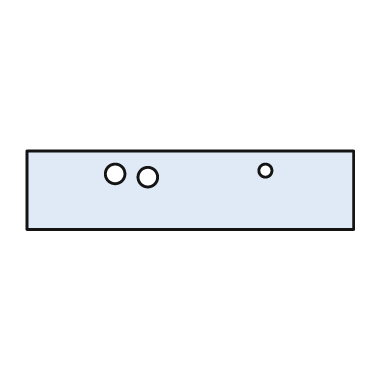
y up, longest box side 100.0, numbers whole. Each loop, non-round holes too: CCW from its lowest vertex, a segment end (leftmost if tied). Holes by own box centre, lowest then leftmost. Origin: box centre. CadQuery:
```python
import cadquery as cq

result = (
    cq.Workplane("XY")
    .moveTo(-50.0, -12.0)
    .lineTo(50.0, -12.0)
    .lineTo(50.0, 12.0)
    .lineTo(-50.0, 12.0)
    .close()
    .moveTo(-13.0, 4.0)
    .circle(3.0)
    .moveTo(-23.0, 5.0)
    .circle(3.0)
    .moveTo(23.0, 6.0)
    .circle(2.0)
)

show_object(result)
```